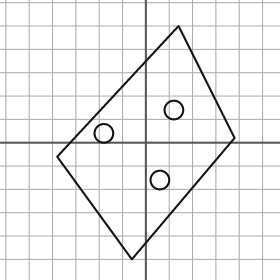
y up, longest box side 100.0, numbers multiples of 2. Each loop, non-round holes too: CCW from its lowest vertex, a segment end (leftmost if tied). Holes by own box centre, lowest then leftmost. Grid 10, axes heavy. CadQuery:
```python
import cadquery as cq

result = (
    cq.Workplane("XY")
    .moveTo(-6.0, -50.0)
    .lineTo(38.0, 2.0)
    .lineTo(14.0, 50.0)
    .lineTo(-38.0, -6.0)
    .close()
    .moveTo(6.0, -16.0)
    .circle(4.0)
    .moveTo(-18.0, 4.0)
    .circle(4.0)
    .moveTo(12.0, 14.0)
    .circle(4.0)
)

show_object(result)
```